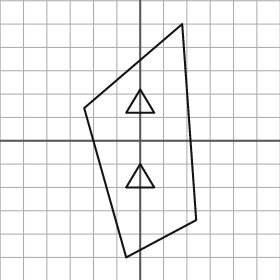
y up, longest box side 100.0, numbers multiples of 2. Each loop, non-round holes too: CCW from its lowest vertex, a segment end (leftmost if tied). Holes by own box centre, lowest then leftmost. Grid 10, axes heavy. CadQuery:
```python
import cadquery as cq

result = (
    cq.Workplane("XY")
    .moveTo(-6.0, -50.0)
    .lineTo(24.0, -34.0)
    .lineTo(18.0, 50.0)
    .lineTo(-24.0, 14.0)
    .close()
    .moveTo(-6.0, -20.0)
    .lineTo(6.0, -20.0)
    .lineTo(0.0, -10.0)
    .close()
    .moveTo(-6.0, 12.0)
    .lineTo(6.0, 12.0)
    .lineTo(0.0, 22.0)
    .close()
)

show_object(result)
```